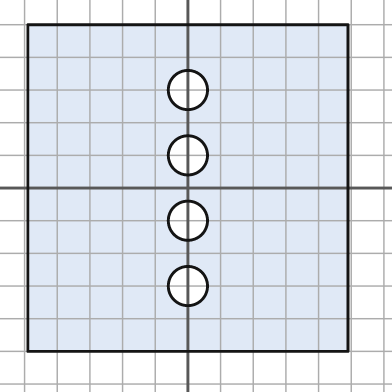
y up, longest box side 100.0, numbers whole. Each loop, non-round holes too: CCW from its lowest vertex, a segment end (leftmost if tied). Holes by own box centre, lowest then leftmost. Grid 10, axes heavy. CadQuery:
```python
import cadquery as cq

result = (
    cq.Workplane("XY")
    .moveTo(-49.0, -50.0)
    .lineTo(49.0, -50.0)
    .lineTo(49.0, 50.0)
    .lineTo(-49.0, 50.0)
    .close()
    .moveTo(0.0, -30.0)
    .circle(6.0)
    .moveTo(0.0, -10.0)
    .circle(6.0)
    .moveTo(0.0, 10.0)
    .circle(6.0)
    .moveTo(0.0, 30.0)
    .circle(6.0)
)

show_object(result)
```